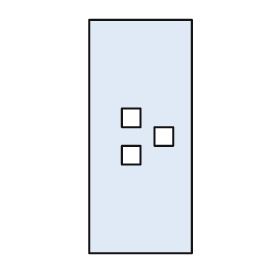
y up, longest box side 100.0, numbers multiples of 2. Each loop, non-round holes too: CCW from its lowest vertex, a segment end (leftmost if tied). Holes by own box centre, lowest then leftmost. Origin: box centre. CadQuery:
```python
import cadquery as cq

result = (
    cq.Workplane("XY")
    .moveTo(-22.0, -50.0)
    .lineTo(22.0, -50.0)
    .lineTo(22.0, 50.0)
    .lineTo(-22.0, 50.0)
    .close()
    .moveTo(-8.0, -12.0)
    .lineTo(0.0, -12.0)
    .lineTo(0.0, -4.0)
    .lineTo(-8.0, -4.0)
    .close()
    .moveTo(6.0, -4.0)
    .lineTo(14.0, -4.0)
    .lineTo(14.0, 4.0)
    .lineTo(6.0, 4.0)
    .close()
    .moveTo(-8.0, 4.0)
    .lineTo(0.0, 4.0)
    .lineTo(0.0, 12.0)
    .lineTo(-8.0, 12.0)
    .close()
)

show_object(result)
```